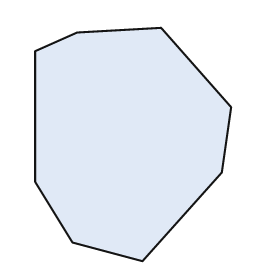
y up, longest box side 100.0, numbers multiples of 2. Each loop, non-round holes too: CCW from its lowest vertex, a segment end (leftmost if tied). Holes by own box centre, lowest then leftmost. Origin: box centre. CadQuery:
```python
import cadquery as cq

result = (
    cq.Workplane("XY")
    .moveTo(4.0, -50.0)
    .lineTo(38.0, -12.0)
    .lineTo(42.0, 16.0)
    .lineTo(12.0, 50.0)
    .lineTo(-24.0, 48.0)
    .lineTo(-42.0, 40.0)
    .lineTo(-42.0, -16.0)
    .lineTo(-26.0, -42.0)
    .close()
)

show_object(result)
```